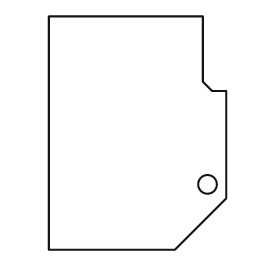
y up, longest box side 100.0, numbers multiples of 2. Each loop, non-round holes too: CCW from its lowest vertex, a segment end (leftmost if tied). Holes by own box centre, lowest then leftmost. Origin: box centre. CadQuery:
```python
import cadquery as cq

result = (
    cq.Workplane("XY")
    .moveTo(-38.0, -50.0)
    .lineTo(16.0, -50.0)
    .lineTo(38.0, -28.0)
    .lineTo(38.0, 18.0)
    .lineTo(32.0, 18.0)
    .lineTo(28.0, 22.0)
    .lineTo(28.0, 50.0)
    .lineTo(-38.0, 50.0)
    .close()
    .moveTo(30.0, -22.0)
    .circle(4.0)
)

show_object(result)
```